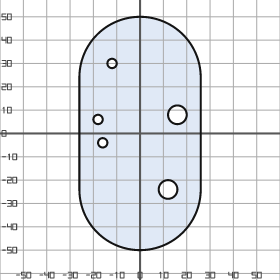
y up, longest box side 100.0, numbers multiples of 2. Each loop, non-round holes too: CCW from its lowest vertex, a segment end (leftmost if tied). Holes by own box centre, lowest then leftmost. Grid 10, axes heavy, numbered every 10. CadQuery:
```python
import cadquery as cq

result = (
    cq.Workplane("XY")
    .moveTo(-26.0, -24.0)
    .threePointArc((0.0, -50.0), (26.0, -24.0))
    .lineTo(26.0, 24.0)
    .threePointArc((0.0, 50.0), (-26.0, 24.0))
    .close()
    .moveTo(12.0, -24.0)
    .circle(4.0)
    .moveTo(-16.0, -4.0)
    .circle(2.0)
    .moveTo(-18.0, 6.0)
    .circle(2.0)
    .moveTo(16.0, 8.0)
    .circle(4.0)
    .moveTo(-12.0, 30.0)
    .circle(2.0)
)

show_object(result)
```